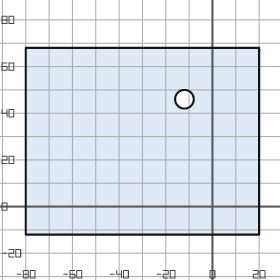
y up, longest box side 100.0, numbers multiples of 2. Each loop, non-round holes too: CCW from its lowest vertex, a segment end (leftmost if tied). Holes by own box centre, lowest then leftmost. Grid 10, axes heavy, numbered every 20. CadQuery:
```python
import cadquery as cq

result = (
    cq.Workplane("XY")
    .moveTo(-80.0, -12.0)
    .lineTo(20.0, -12.0)
    .lineTo(20.0, 68.0)
    .lineTo(-80.0, 68.0)
    .close()
    .moveTo(-12.0, 46.0)
    .circle(4.0)
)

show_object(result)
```